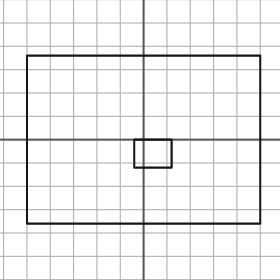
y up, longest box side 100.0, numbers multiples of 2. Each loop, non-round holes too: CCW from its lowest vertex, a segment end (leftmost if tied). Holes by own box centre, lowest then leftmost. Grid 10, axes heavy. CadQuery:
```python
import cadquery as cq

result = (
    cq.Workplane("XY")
    .moveTo(-50.0, -36.0)
    .lineTo(50.0, -36.0)
    .lineTo(50.0, 36.0)
    .lineTo(-50.0, 36.0)
    .close()
    .moveTo(-4.0, -12.0)
    .lineTo(12.0, -12.0)
    .lineTo(12.0, 0.0)
    .lineTo(-4.0, 0.0)
    .close()
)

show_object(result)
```